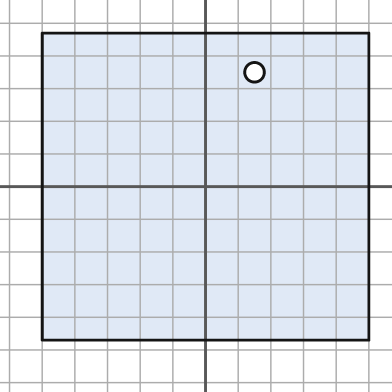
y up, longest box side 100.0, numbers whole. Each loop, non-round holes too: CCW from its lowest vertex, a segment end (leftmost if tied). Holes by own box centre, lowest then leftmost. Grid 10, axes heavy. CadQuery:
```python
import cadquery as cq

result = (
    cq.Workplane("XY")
    .moveTo(-50.0, -47.0)
    .lineTo(50.0, -47.0)
    .lineTo(50.0, 47.0)
    .lineTo(-50.0, 47.0)
    .close()
    .moveTo(15.0, 35.0)
    .circle(3.0)
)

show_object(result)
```